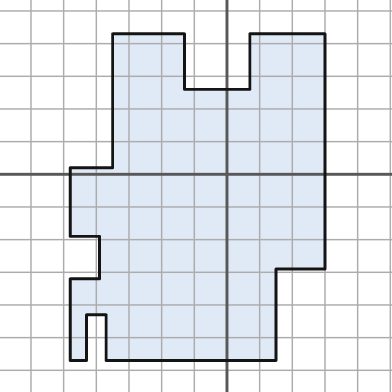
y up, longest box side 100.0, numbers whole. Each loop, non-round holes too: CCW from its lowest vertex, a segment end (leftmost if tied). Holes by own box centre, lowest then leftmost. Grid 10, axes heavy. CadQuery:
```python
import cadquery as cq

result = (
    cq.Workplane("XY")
    .moveTo(-48.0, -57.0)
    .lineTo(-43.0, -57.0)
    .lineTo(-43.0, -43.0)
    .lineTo(-37.0, -43.0)
    .lineTo(-37.0, -57.0)
    .lineTo(15.0, -57.0)
    .lineTo(15.0, -29.0)
    .lineTo(30.0, -29.0)
    .lineTo(30.0, 43.0)
    .lineTo(7.0, 43.0)
    .lineTo(7.0, 26.0)
    .lineTo(-13.0, 26.0)
    .lineTo(-13.0, 43.0)
    .lineTo(-35.0, 43.0)
    .lineTo(-35.0, 2.0)
    .lineTo(-48.0, 2.0)
    .lineTo(-48.0, -19.0)
    .lineTo(-39.0, -19.0)
    .lineTo(-39.0, -32.0)
    .lineTo(-48.0, -32.0)
    .close()
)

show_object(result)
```